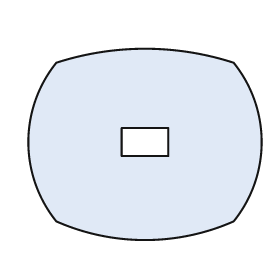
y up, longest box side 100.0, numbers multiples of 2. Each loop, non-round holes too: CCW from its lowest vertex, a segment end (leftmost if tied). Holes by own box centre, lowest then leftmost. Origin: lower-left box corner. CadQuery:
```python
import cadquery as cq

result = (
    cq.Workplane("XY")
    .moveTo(12.0, 8.0)
    .threePointArc((50.0, 0.0), (88.0, 8.0))
    .threePointArc((100.0, 42.0), (88.0, 76.0))
    .threePointArc((50.0, 82.0), (12.0, 76.0))
    .threePointArc((0.0, 42.0), (12.0, 8.0))
    .close()
    .moveTo(40.0, 36.0)
    .lineTo(60.0, 36.0)
    .lineTo(60.0, 48.0)
    .lineTo(40.0, 48.0)
    .close()
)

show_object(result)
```